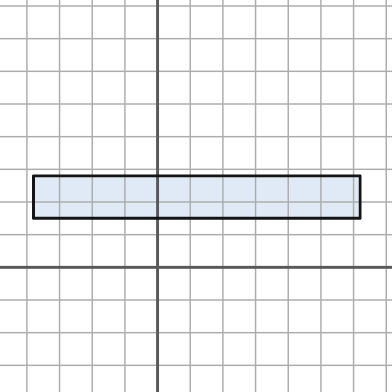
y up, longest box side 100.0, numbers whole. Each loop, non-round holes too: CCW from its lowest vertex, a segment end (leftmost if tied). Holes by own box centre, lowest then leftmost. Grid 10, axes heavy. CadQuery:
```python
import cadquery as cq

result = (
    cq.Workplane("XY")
    .moveTo(-38.0, 15.0)
    .lineTo(62.0, 15.0)
    .lineTo(62.0, 28.0)
    .lineTo(-38.0, 28.0)
    .close()
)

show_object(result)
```